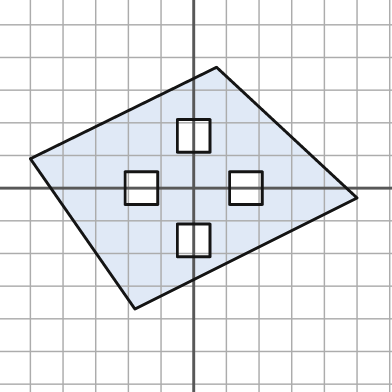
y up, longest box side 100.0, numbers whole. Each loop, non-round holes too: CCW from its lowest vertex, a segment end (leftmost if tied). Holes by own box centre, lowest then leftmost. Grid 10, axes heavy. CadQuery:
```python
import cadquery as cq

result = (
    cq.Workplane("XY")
    .moveTo(-18.0, -37.0)
    .lineTo(50.0, -3.0)
    .lineTo(7.0, 37.0)
    .lineTo(-50.0, 9.0)
    .close()
    .moveTo(-5.0, -21.0)
    .lineTo(5.0, -21.0)
    .lineTo(5.0, -11.0)
    .lineTo(-5.0, -11.0)
    .close()
    .moveTo(-21.0, -5.0)
    .lineTo(-11.0, -5.0)
    .lineTo(-11.0, 5.0)
    .lineTo(-21.0, 5.0)
    .close()
    .moveTo(11.0, -5.0)
    .lineTo(21.0, -5.0)
    .lineTo(21.0, 5.0)
    .lineTo(11.0, 5.0)
    .close()
    .moveTo(-5.0, 11.0)
    .lineTo(5.0, 11.0)
    .lineTo(5.0, 21.0)
    .lineTo(-5.0, 21.0)
    .close()
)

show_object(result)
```